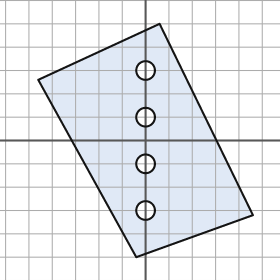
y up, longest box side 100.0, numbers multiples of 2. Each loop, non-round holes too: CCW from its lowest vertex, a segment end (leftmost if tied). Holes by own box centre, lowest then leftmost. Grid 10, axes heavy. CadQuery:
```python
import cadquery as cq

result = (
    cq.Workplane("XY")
    .moveTo(-4.0, -50.0)
    .lineTo(46.0, -32.0)
    .lineTo(6.0, 50.0)
    .lineTo(-46.0, 26.0)
    .close()
    .moveTo(0.0, -30.0)
    .circle(4.0)
    .moveTo(0.0, -10.0)
    .circle(4.0)
    .moveTo(0.0, 10.0)
    .circle(4.0)
    .moveTo(0.0, 30.0)
    .circle(4.0)
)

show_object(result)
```